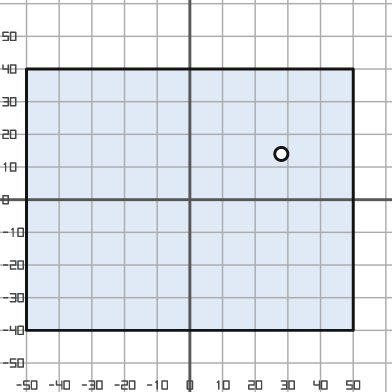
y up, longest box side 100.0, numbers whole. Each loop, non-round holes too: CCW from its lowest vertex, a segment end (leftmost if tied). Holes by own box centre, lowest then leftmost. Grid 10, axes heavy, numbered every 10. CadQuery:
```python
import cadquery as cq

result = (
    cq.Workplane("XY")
    .moveTo(-50.0, -40.0)
    .lineTo(50.0, -40.0)
    .lineTo(50.0, 40.0)
    .lineTo(-50.0, 40.0)
    .close()
    .moveTo(28.0, 14.0)
    .circle(2.0)
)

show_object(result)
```